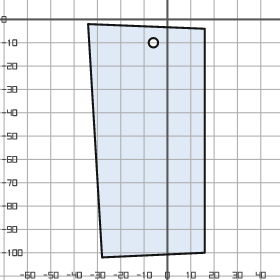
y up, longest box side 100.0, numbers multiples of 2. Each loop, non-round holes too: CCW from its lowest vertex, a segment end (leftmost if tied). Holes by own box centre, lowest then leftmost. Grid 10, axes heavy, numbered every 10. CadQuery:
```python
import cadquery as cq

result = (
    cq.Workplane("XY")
    .moveTo(-28.0, -102.0)
    .lineTo(16.0, -100.0)
    .lineTo(16.0, -4.0)
    .lineTo(-34.0, -2.0)
    .close()
    .moveTo(-6.0, -10.0)
    .circle(2.0)
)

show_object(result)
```